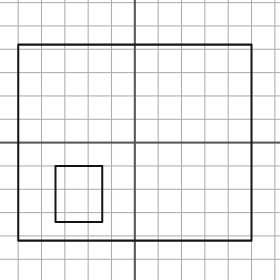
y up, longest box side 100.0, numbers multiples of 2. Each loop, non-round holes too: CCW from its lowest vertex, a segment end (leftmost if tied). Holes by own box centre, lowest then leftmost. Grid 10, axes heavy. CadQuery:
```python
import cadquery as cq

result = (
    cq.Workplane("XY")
    .moveTo(-50.0, -42.0)
    .lineTo(50.0, -42.0)
    .lineTo(50.0, 42.0)
    .lineTo(-50.0, 42.0)
    .close()
    .moveTo(-34.0, -34.0)
    .lineTo(-14.0, -34.0)
    .lineTo(-14.0, -10.0)
    .lineTo(-34.0, -10.0)
    .close()
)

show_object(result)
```